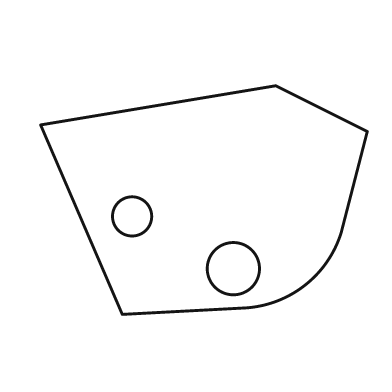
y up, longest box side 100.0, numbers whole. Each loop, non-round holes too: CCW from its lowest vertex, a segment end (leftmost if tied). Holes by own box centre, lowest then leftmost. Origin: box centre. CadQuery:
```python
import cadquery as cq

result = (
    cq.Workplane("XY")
    .moveTo(-25.0, -35.0)
    .lineTo(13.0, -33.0)
    .threePointArc((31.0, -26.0), (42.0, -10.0))
    .lineTo(50.0, 21.0)
    .lineTo(22.0, 35.0)
    .lineTo(-50.0, 23.0)
    .close()
    .moveTo(9.0, -21.0)
    .circle(8.0)
    .moveTo(-22.0, -5.0)
    .circle(6.0)
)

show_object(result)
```